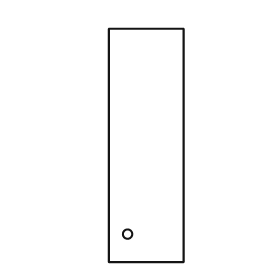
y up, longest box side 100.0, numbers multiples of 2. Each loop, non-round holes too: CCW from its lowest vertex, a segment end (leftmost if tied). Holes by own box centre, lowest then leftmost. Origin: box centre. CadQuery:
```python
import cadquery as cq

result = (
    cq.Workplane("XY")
    .moveTo(-16.0, -50.0)
    .lineTo(16.0, -50.0)
    .lineTo(16.0, 50.0)
    .lineTo(-16.0, 50.0)
    .close()
    .moveTo(-8.0, -38.0)
    .circle(2.0)
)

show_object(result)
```